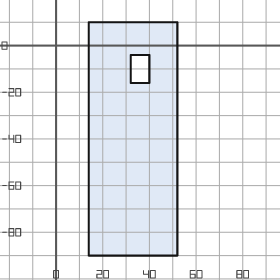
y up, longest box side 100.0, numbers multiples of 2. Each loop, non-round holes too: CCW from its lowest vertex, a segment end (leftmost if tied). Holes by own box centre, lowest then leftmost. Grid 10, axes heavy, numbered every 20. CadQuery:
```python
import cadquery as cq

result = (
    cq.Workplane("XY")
    .moveTo(14.0, -90.0)
    .lineTo(52.0, -90.0)
    .lineTo(52.0, 10.0)
    .lineTo(14.0, 10.0)
    .close()
    .moveTo(32.0, -16.0)
    .lineTo(40.0, -16.0)
    .lineTo(40.0, -4.0)
    .lineTo(32.0, -4.0)
    .close()
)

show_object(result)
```